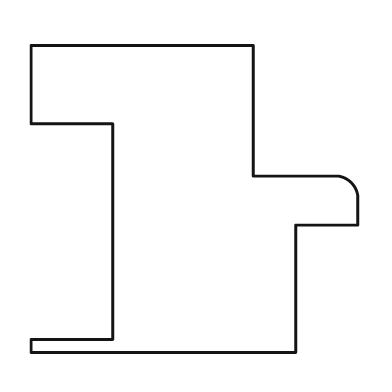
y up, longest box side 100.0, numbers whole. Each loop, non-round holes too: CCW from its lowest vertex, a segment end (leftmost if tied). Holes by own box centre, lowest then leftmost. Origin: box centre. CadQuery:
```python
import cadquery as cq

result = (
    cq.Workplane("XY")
    .moveTo(-50.0, -47.0)
    .lineTo(31.0, -47.0)
    .lineTo(31.0, -8.0)
    .lineTo(50.0, -8.0)
    .lineTo(50.0, 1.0)
    .threePointArc((48.0, 5.0), (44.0, 7.0))
    .lineTo(18.0, 7.0)
    .lineTo(18.0, 47.0)
    .lineTo(-50.0, 47.0)
    .lineTo(-50.0, 23.0)
    .lineTo(-25.0, 23.0)
    .lineTo(-25.0, -43.0)
    .lineTo(-50.0, -43.0)
    .close()
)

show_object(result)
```